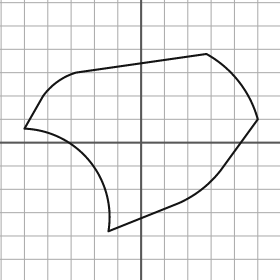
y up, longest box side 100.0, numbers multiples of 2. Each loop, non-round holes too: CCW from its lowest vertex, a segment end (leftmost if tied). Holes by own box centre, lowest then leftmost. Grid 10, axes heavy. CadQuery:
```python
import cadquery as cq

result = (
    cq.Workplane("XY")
    .moveTo(-14.0, -38.0)
    .lineTo(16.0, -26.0)
    .threePointArc((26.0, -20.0), (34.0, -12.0))
    .lineTo(50.0, 10.0)
    .threePointArc((42.0, 26.0), (28.0, 38.0))
    .lineTo(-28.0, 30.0)
    .threePointArc((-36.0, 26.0), (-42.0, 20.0))
    .lineTo(-50.0, 6.0)
    .threePointArc((-22.0, -8.0), (-14.0, -38.0))
    .close()
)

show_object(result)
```